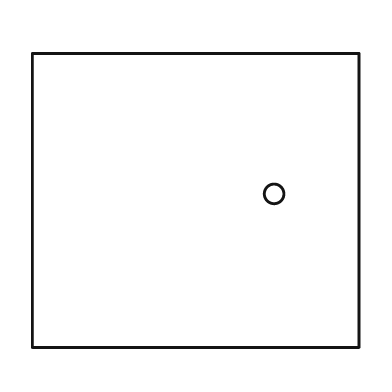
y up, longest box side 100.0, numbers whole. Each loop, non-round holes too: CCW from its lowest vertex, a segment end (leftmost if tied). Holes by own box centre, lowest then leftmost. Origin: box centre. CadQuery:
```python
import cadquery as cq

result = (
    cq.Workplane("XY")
    .moveTo(-50.0, -45.0)
    .lineTo(50.0, -45.0)
    .lineTo(50.0, 45.0)
    .lineTo(-50.0, 45.0)
    .close()
    .moveTo(24.0, 2.0)
    .circle(3.0)
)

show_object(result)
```